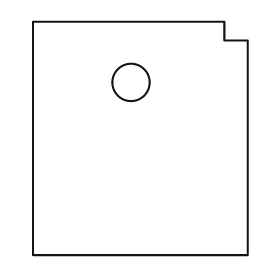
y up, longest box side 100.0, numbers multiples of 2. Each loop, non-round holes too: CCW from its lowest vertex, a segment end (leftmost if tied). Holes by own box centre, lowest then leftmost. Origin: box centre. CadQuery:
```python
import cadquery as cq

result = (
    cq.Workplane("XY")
    .moveTo(-46.0, -50.0)
    .lineTo(46.0, -50.0)
    .lineTo(46.0, 42.0)
    .lineTo(36.0, 42.0)
    .lineTo(36.0, 50.0)
    .lineTo(-46.0, 50.0)
    .close()
    .moveTo(-4.0, 24.0)
    .circle(8.0)
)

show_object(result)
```